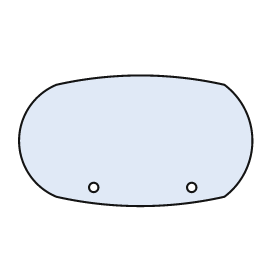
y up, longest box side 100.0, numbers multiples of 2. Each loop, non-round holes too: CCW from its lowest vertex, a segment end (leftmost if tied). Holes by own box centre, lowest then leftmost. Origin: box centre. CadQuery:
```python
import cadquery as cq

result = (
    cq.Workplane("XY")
    .moveTo(-34.0, -24.0)
    .threePointArc((2.0, -28.0), (38.0, -24.0))
    .threePointArc((50.0, 0.0), (38.0, 24.0))
    .threePointArc((2.0, 28.0), (-34.0, 24.0))
    .threePointArc((-50.0, 0.0), (-34.0, -24.0))
    .close()
    .moveTo(-18.0, -20.0)
    .circle(2.0)
    .moveTo(24.0, -20.0)
    .circle(2.0)
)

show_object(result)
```